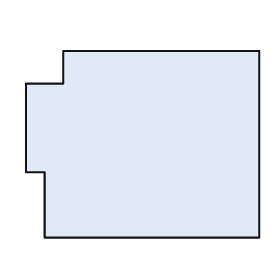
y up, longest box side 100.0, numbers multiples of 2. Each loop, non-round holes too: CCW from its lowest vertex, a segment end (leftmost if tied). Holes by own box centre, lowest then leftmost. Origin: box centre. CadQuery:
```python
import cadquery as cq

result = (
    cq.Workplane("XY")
    .moveTo(-42.0, -40.0)
    .lineTo(50.0, -40.0)
    .lineTo(50.0, 40.0)
    .lineTo(-34.0, 40.0)
    .lineTo(-34.0, 26.0)
    .lineTo(-50.0, 26.0)
    .lineTo(-50.0, -12.0)
    .lineTo(-42.0, -12.0)
    .close()
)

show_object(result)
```